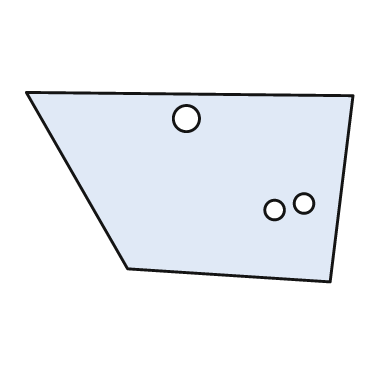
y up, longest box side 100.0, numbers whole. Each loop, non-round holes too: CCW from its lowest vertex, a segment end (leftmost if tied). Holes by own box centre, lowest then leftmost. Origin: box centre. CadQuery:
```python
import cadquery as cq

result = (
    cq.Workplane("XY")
    .moveTo(43.0, -29.0)
    .lineTo(50.0, 28.0)
    .lineTo(-50.0, 29.0)
    .lineTo(-19.0, -25.0)
    .close()
    .moveTo(26.0, -7.0)
    .circle(3.0)
    .moveTo(35.0, -5.0)
    .circle(3.0)
    .moveTo(-1.0, 21.0)
    .circle(4.0)
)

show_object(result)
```